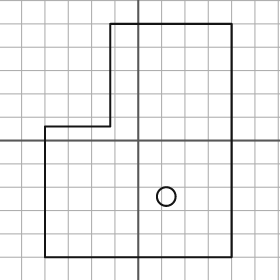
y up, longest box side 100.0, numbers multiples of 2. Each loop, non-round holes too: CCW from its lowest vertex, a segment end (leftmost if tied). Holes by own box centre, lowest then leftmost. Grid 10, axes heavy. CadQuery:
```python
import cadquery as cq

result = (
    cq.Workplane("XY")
    .moveTo(-40.0, -50.0)
    .lineTo(40.0, -50.0)
    .lineTo(40.0, 50.0)
    .lineTo(-12.0, 50.0)
    .lineTo(-12.0, 6.0)
    .lineTo(-40.0, 6.0)
    .close()
    .moveTo(12.0, -24.0)
    .circle(4.0)
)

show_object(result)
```